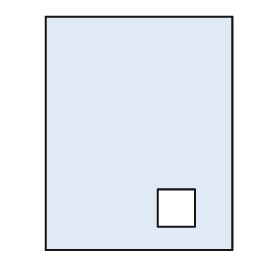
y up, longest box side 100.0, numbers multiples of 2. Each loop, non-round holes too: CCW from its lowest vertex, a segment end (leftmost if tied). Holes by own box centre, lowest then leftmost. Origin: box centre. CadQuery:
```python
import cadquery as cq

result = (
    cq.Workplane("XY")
    .moveTo(-40.0, -50.0)
    .lineTo(40.0, -50.0)
    .lineTo(40.0, 50.0)
    .lineTo(-40.0, 50.0)
    .close()
    .moveTo(8.0, -40.0)
    .lineTo(24.0, -40.0)
    .lineTo(24.0, -24.0)
    .lineTo(8.0, -24.0)
    .close()
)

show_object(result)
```